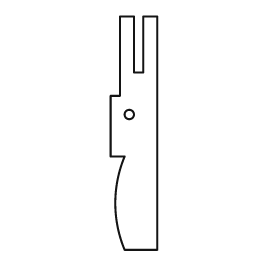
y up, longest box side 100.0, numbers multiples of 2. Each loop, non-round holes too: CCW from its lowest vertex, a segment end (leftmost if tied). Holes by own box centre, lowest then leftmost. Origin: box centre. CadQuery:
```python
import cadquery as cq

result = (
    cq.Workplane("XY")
    .moveTo(-4.0, -50.0)
    .lineTo(10.0, -50.0)
    .lineTo(10.0, 50.0)
    .lineTo(4.0, 50.0)
    .lineTo(4.0, 26.0)
    .lineTo(0.0, 26.0)
    .lineTo(0.0, 50.0)
    .lineTo(-6.0, 50.0)
    .lineTo(-6.0, 16.0)
    .lineTo(-10.0, 16.0)
    .lineTo(-10.0, -10.0)
    .lineTo(-4.0, -10.0)
    .threePointArc((-8.0, -30.0), (-4.0, -50.0))
    .close()
    .moveTo(-2.0, 8.0)
    .circle(2.0)
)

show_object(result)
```